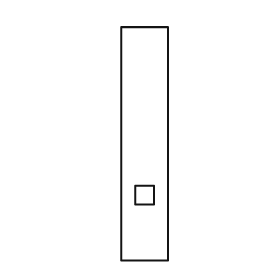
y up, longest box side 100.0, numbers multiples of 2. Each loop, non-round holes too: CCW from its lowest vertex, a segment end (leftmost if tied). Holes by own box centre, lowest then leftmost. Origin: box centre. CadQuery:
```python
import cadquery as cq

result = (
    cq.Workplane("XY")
    .moveTo(-10.0, -50.0)
    .lineTo(10.0, -50.0)
    .lineTo(10.0, 50.0)
    .lineTo(-10.0, 50.0)
    .close()
    .moveTo(-4.0, -26.0)
    .lineTo(4.0, -26.0)
    .lineTo(4.0, -18.0)
    .lineTo(-4.0, -18.0)
    .close()
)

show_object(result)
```